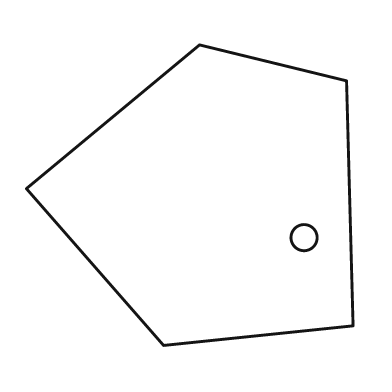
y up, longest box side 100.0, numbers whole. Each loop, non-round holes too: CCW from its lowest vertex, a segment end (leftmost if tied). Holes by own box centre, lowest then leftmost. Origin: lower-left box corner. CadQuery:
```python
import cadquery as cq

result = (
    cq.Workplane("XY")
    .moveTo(42.0, 0.0)
    .lineTo(100.0, 6.0)
    .lineTo(98.0, 81.0)
    .lineTo(53.0, 92.0)
    .lineTo(0.0, 48.0)
    .close()
    .moveTo(85.0, 33.0)
    .circle(4.0)
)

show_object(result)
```